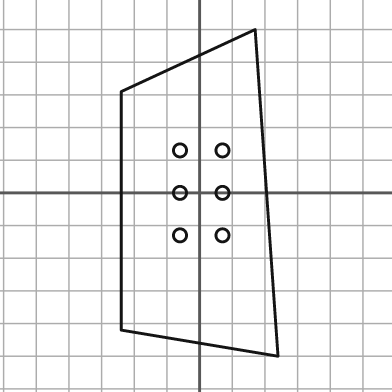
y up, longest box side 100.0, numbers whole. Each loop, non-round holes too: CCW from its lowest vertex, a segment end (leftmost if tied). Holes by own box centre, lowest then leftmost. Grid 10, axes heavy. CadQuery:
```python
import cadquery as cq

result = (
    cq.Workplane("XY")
    .moveTo(24.0, -50.0)
    .lineTo(17.0, 50.0)
    .lineTo(-24.0, 31.0)
    .lineTo(-24.0, -42.0)
    .close()
    .moveTo(-6.0, -13.0)
    .circle(2.0)
    .moveTo(7.0, -13.0)
    .circle(2.0)
    .moveTo(-6.0, 0.0)
    .circle(2.0)
    .moveTo(7.0, 0.0)
    .circle(2.0)
    .moveTo(-6.0, 13.0)
    .circle(2.0)
    .moveTo(7.0, 13.0)
    .circle(2.0)
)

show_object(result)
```